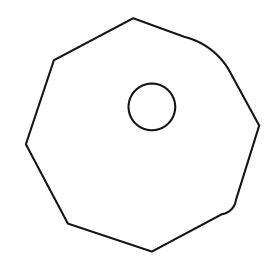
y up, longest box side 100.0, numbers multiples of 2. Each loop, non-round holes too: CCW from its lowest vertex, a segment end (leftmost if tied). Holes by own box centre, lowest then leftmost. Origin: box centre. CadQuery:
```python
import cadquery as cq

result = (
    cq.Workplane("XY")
    .moveTo(4.0, -50.0)
    .lineTo(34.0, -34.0)
    .threePointArc((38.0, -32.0), (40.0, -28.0))
    .lineTo(50.0, 4.0)
    .lineTo(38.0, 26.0)
    .threePointArc((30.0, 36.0), (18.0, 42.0))
    .lineTo(-4.0, 50.0)
    .lineTo(-38.0, 32.0)
    .lineTo(-50.0, -4.0)
    .lineTo(-32.0, -38.0)
    .close()
    .moveTo(4.0, 12.0)
    .circle(10.0)
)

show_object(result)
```